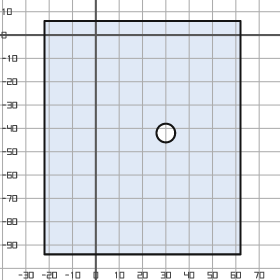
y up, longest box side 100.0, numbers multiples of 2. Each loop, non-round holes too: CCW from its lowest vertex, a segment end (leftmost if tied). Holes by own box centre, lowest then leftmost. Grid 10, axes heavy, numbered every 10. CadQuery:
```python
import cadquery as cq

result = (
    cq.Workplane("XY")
    .moveTo(-22.0, -94.0)
    .lineTo(62.0, -94.0)
    .lineTo(62.0, 6.0)
    .lineTo(-22.0, 6.0)
    .close()
    .moveTo(30.0, -42.0)
    .circle(4.0)
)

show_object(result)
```